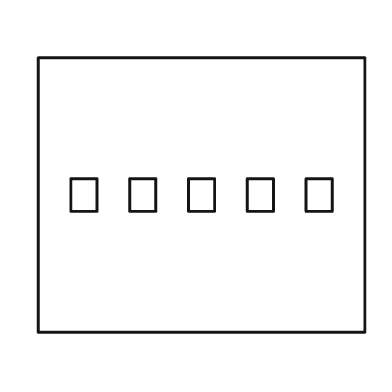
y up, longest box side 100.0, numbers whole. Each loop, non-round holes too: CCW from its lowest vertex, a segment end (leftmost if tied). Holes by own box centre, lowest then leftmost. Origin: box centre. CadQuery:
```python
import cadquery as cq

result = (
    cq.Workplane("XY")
    .moveTo(-50.0, -42.0)
    .lineTo(50.0, -42.0)
    .lineTo(50.0, 42.0)
    .lineTo(-50.0, 42.0)
    .close()
    .moveTo(-40.0, -5.0)
    .lineTo(-32.0, -5.0)
    .lineTo(-32.0, 5.0)
    .lineTo(-40.0, 5.0)
    .close()
    .moveTo(-22.0, -5.0)
    .lineTo(-14.0, -5.0)
    .lineTo(-14.0, 5.0)
    .lineTo(-22.0, 5.0)
    .close()
    .moveTo(-4.0, -5.0)
    .lineTo(4.0, -5.0)
    .lineTo(4.0, 5.0)
    .lineTo(-4.0, 5.0)
    .close()
    .moveTo(14.0, -5.0)
    .lineTo(22.0, -5.0)
    .lineTo(22.0, 5.0)
    .lineTo(14.0, 5.0)
    .close()
    .moveTo(32.0, -5.0)
    .lineTo(40.0, -5.0)
    .lineTo(40.0, 5.0)
    .lineTo(32.0, 5.0)
    .close()
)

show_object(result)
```